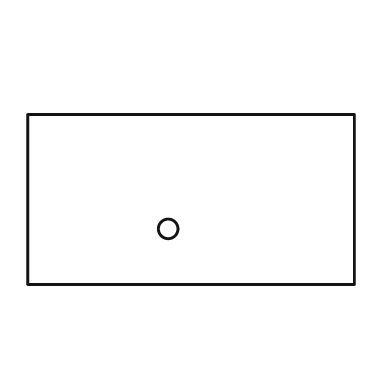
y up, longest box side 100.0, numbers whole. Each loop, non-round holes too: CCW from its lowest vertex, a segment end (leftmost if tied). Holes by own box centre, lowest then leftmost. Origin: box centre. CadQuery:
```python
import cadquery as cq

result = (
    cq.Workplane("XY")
    .moveTo(-50.0, -26.0)
    .lineTo(50.0, -26.0)
    .lineTo(50.0, 26.0)
    .lineTo(-50.0, 26.0)
    .close()
    .moveTo(-7.0, -9.0)
    .circle(3.0)
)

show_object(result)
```